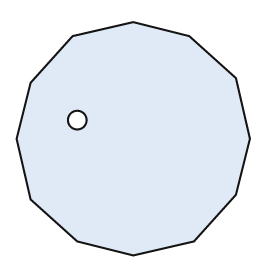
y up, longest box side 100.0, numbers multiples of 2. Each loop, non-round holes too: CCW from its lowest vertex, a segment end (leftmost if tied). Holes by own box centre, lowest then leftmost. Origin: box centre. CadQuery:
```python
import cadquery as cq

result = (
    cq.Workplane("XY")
    .moveTo(0.0, -50.0)
    .lineTo(26.0, -44.0)
    .lineTo(44.0, -24.0)
    .lineTo(50.0, 0.0)
    .lineTo(44.0, 26.0)
    .lineTo(24.0, 44.0)
    .lineTo(0.0, 50.0)
    .lineTo(-26.0, 44.0)
    .lineTo(-44.0, 24.0)
    .lineTo(-50.0, 0.0)
    .lineTo(-44.0, -26.0)
    .lineTo(-24.0, -44.0)
    .close()
    .moveTo(-24.0, 8.0)
    .circle(4.0)
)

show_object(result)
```